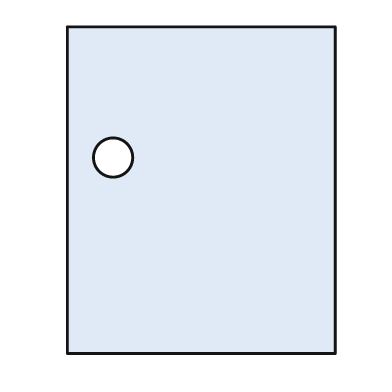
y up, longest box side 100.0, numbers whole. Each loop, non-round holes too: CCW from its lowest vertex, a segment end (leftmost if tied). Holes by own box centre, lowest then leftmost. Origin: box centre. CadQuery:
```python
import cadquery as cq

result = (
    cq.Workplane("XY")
    .moveTo(-41.0, -50.0)
    .lineTo(41.0, -50.0)
    .lineTo(41.0, 50.0)
    .lineTo(-41.0, 50.0)
    .close()
    .moveTo(-27.0, 10.0)
    .circle(6.0)
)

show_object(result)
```